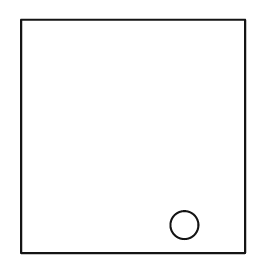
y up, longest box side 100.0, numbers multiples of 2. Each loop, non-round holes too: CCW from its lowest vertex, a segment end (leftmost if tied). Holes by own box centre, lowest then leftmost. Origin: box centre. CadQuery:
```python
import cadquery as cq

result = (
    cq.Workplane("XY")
    .moveTo(-48.0, -50.0)
    .lineTo(48.0, -50.0)
    .lineTo(48.0, 50.0)
    .lineTo(-48.0, 50.0)
    .close()
    .moveTo(22.0, -38.0)
    .circle(6.0)
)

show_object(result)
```